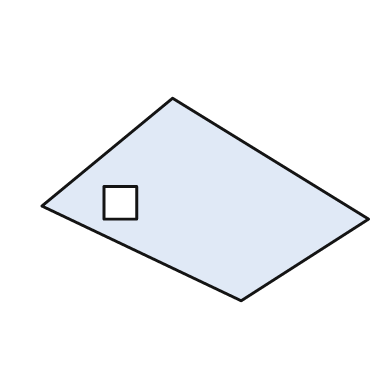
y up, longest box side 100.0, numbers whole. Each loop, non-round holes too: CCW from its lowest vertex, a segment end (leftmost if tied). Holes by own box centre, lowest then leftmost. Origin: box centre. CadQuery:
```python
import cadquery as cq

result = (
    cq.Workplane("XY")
    .moveTo(11.0, -31.0)
    .lineTo(50.0, -6.0)
    .lineTo(-10.0, 31.0)
    .lineTo(-50.0, -2.0)
    .close()
    .moveTo(-31.0, -6.0)
    .lineTo(-21.0, -6.0)
    .lineTo(-21.0, 4.0)
    .lineTo(-31.0, 4.0)
    .close()
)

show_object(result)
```